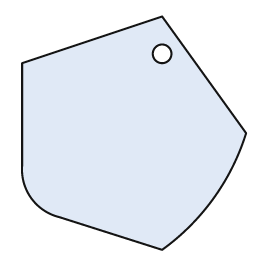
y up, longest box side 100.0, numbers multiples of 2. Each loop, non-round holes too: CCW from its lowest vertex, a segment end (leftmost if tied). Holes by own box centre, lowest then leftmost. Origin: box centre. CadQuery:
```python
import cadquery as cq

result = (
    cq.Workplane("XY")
    .moveTo(12.0, -50.0)
    .threePointArc((34.0, -28.0), (48.0, 0.0))
    .lineTo(12.0, 50.0)
    .lineTo(-48.0, 30.0)
    .lineTo(-48.0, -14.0)
    .threePointArc((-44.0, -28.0), (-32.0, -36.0))
    .close()
    .moveTo(12.0, 34.0)
    .circle(4.0)
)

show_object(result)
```